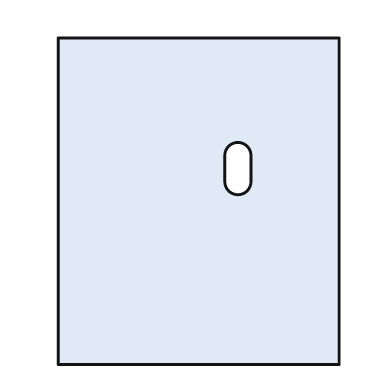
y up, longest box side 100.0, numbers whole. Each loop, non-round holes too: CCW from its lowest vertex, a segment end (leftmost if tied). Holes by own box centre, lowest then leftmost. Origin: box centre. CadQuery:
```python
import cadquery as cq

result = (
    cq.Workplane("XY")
    .moveTo(-43.0, -50.0)
    .lineTo(43.0, -50.0)
    .lineTo(43.0, 50.0)
    .lineTo(-43.0, 50.0)
    .close()
    .moveTo(8.0, 6.0)
    .threePointArc((12.0, 2.0), (16.0, 6.0))
    .lineTo(16.0, 14.0)
    .threePointArc((12.0, 18.0), (8.0, 14.0))
    .close()
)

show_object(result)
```